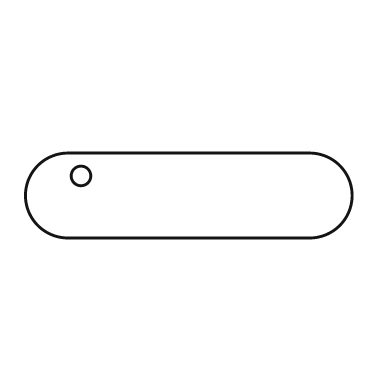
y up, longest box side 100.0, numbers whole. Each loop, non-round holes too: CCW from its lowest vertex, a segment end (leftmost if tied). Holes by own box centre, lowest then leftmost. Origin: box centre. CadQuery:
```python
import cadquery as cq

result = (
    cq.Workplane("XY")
    .moveTo(-37.0, -13.0)
    .lineTo(37.0, -13.0)
    .threePointArc((50.0, 0.0), (37.0, 13.0))
    .lineTo(-37.0, 13.0)
    .threePointArc((-50.0, 0.0), (-37.0, -13.0))
    .close()
    .moveTo(-33.0, 6.0)
    .circle(3.0)
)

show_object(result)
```